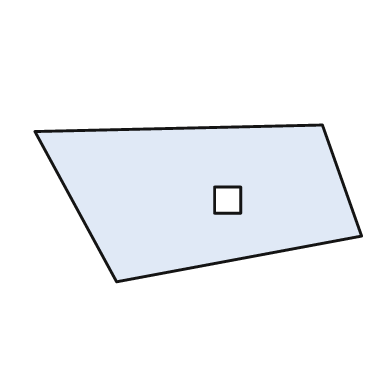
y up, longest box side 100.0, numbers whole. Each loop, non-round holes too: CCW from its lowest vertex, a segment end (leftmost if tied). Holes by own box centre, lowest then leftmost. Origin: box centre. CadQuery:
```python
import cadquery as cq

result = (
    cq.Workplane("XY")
    .moveTo(-25.0, -24.0)
    .lineTo(50.0, -10.0)
    .lineTo(38.0, 24.0)
    .lineTo(-50.0, 22.0)
    .close()
    .moveTo(5.0, -3.0)
    .lineTo(13.0, -3.0)
    .lineTo(13.0, 5.0)
    .lineTo(5.0, 5.0)
    .close()
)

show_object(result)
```